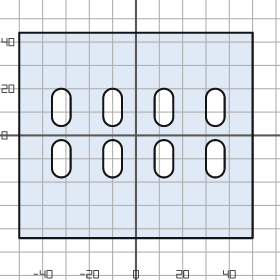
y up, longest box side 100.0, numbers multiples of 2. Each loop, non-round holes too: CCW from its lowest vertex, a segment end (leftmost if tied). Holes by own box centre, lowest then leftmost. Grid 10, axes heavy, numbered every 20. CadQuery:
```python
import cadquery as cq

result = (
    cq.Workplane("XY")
    .moveTo(-50.0, -44.0)
    .lineTo(50.0, -44.0)
    .lineTo(50.0, 44.0)
    .lineTo(-50.0, 44.0)
    .close()
    .moveTo(-36.0, -14.0)
    .threePointArc((-32.0, -18.0), (-28.0, -14.0))
    .lineTo(-28.0, -6.0)
    .threePointArc((-32.0, -2.0), (-36.0, -6.0))
    .close()
    .moveTo(-14.0, -14.0)
    .threePointArc((-10.0, -18.0), (-6.0, -14.0))
    .lineTo(-6.0, -6.0)
    .threePointArc((-10.0, -2.0), (-14.0, -6.0))
    .close()
    .moveTo(8.0, -14.0)
    .threePointArc((12.0, -18.0), (16.0, -14.0))
    .lineTo(16.0, -6.0)
    .threePointArc((12.0, -2.0), (8.0, -6.0))
    .close()
    .moveTo(30.0, -14.0)
    .threePointArc((34.0, -18.0), (38.0, -14.0))
    .lineTo(38.0, -6.0)
    .threePointArc((34.0, -2.0), (30.0, -6.0))
    .close()
    .moveTo(-36.0, 8.0)
    .threePointArc((-32.0, 4.0), (-28.0, 8.0))
    .lineTo(-28.0, 16.0)
    .threePointArc((-32.0, 20.0), (-36.0, 16.0))
    .close()
    .moveTo(-14.0, 8.0)
    .threePointArc((-10.0, 4.0), (-6.0, 8.0))
    .lineTo(-6.0, 16.0)
    .threePointArc((-10.0, 20.0), (-14.0, 16.0))
    .close()
    .moveTo(8.0, 8.0)
    .threePointArc((12.0, 4.0), (16.0, 8.0))
    .lineTo(16.0, 16.0)
    .threePointArc((12.0, 20.0), (8.0, 16.0))
    .close()
    .moveTo(30.0, 8.0)
    .threePointArc((34.0, 4.0), (38.0, 8.0))
    .lineTo(38.0, 16.0)
    .threePointArc((34.0, 20.0), (30.0, 16.0))
    .close()
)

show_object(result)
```